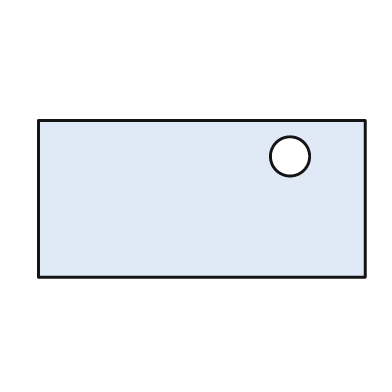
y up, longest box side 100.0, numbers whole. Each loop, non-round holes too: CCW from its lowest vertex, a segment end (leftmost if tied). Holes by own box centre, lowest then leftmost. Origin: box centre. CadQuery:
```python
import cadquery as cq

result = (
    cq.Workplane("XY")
    .moveTo(-50.0, -24.0)
    .lineTo(50.0, -24.0)
    .lineTo(50.0, 24.0)
    .lineTo(-50.0, 24.0)
    .close()
    .moveTo(27.0, 13.0)
    .circle(6.0)
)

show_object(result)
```